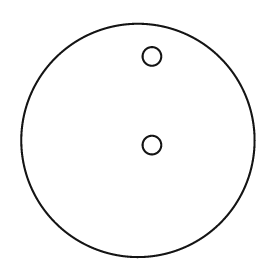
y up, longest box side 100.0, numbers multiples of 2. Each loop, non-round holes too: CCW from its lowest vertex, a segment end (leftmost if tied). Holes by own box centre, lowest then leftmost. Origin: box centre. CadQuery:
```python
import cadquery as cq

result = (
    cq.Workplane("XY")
    .moveTo(0.0, 0.0)
    .circle(50.0)
    .moveTo(6.0, -2.0)
    .circle(4.0)
    .moveTo(6.0, 36.0)
    .circle(4.0)
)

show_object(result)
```